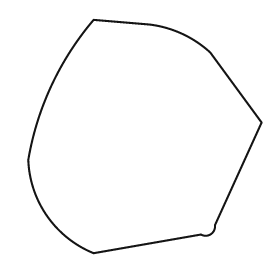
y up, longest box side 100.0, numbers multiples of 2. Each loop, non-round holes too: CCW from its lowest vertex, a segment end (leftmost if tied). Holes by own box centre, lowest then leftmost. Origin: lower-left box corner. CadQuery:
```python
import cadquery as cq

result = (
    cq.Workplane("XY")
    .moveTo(28.0, 0.0)
    .lineTo(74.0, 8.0)
    .threePointArc((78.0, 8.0), (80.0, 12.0))
    .lineTo(100.0, 56.0)
    .lineTo(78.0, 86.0)
    .threePointArc((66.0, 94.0), (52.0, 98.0))
    .lineTo(28.0, 100.0)
    .threePointArc((10.0, 72.0), (0.0, 40.0))
    .threePointArc((8.0, 16.0), (28.0, 0.0))
    .close()
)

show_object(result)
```